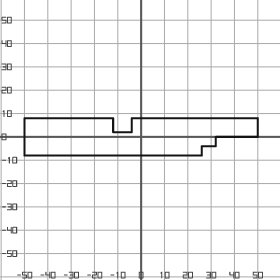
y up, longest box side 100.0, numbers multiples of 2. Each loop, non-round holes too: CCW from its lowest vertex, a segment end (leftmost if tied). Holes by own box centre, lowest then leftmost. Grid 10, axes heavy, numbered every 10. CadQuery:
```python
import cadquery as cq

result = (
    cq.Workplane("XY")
    .moveTo(-50.0, -8.0)
    .lineTo(26.0, -8.0)
    .lineTo(26.0, -4.0)
    .lineTo(32.0, -4.0)
    .lineTo(32.0, 0.0)
    .lineTo(50.0, 0.0)
    .lineTo(50.0, 8.0)
    .lineTo(-4.0, 8.0)
    .lineTo(-4.0, 2.0)
    .lineTo(-12.0, 2.0)
    .lineTo(-12.0, 8.0)
    .lineTo(-50.0, 8.0)
    .close()
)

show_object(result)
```